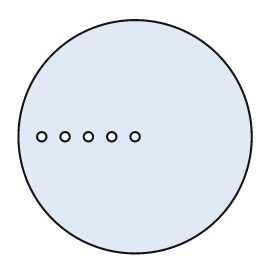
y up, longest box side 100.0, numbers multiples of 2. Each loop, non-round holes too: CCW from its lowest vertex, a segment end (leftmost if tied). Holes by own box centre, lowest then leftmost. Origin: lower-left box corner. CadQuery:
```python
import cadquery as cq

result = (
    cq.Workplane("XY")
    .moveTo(50.0, 50.0)
    .circle(50.0)
    .moveTo(10.0, 50.0)
    .circle(2.0)
    .moveTo(20.0, 50.0)
    .circle(2.0)
    .moveTo(30.0, 50.0)
    .circle(2.0)
    .moveTo(40.0, 50.0)
    .circle(2.0)
    .moveTo(50.0, 50.0)
    .circle(2.0)
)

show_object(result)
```